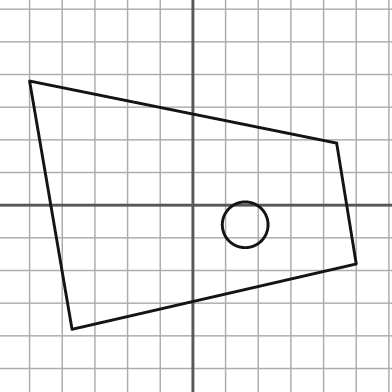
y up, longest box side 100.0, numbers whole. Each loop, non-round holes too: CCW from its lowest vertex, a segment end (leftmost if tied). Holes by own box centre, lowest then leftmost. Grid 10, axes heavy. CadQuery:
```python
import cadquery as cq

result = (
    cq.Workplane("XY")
    .moveTo(-37.0, -38.0)
    .lineTo(50.0, -18.0)
    .lineTo(44.0, 19.0)
    .lineTo(-50.0, 38.0)
    .close()
    .moveTo(16.0, -6.0)
    .circle(7.0)
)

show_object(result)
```